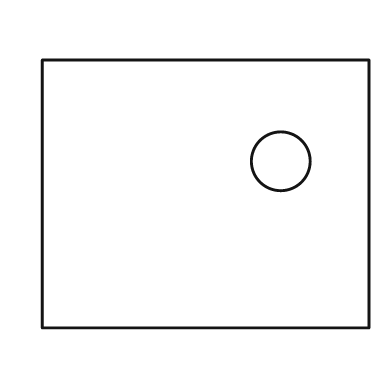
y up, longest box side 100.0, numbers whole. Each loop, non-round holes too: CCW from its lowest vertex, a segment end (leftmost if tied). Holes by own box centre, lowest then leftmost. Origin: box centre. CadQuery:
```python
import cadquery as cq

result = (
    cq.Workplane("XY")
    .moveTo(-50.0, -41.0)
    .lineTo(50.0, -41.0)
    .lineTo(50.0, 41.0)
    .lineTo(-50.0, 41.0)
    .close()
    .moveTo(23.0, 10.0)
    .circle(9.0)
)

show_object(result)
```